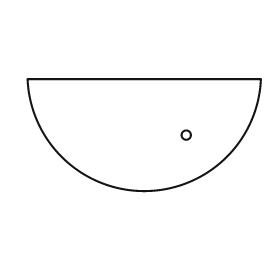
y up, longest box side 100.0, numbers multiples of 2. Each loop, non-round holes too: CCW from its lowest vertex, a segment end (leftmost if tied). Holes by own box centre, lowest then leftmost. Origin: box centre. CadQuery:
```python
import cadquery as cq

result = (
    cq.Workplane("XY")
    .moveTo(-50.0, 24.0)
    .threePointArc((0.0, -24.0), (50.0, 24.0))
    .close()
    .moveTo(18.0, 0.0)
    .circle(2.0)
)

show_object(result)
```